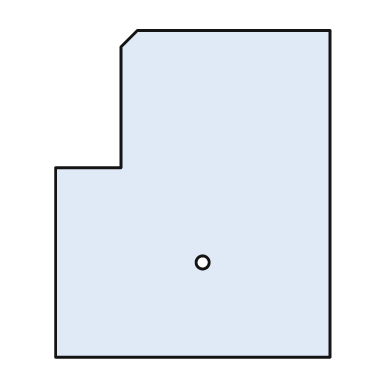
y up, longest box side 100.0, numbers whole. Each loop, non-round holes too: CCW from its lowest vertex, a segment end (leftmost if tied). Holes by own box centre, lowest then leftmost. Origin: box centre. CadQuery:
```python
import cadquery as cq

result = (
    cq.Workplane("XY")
    .moveTo(-42.0, -50.0)
    .lineTo(42.0, -50.0)
    .lineTo(42.0, 50.0)
    .lineTo(-17.0, 50.0)
    .lineTo(-22.0, 45.0)
    .lineTo(-22.0, 8.0)
    .lineTo(-42.0, 8.0)
    .close()
    .moveTo(3.0, -21.0)
    .circle(2.0)
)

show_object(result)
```